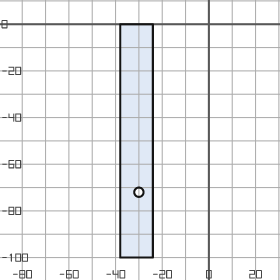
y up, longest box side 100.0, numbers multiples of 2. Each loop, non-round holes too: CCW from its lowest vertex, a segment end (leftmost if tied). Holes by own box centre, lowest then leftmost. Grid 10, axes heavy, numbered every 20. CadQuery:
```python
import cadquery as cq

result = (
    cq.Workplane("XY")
    .moveTo(-38.0, -100.0)
    .lineTo(-24.0, -100.0)
    .lineTo(-24.0, 0.0)
    .lineTo(-38.0, 0.0)
    .close()
    .moveTo(-30.0, -72.0)
    .circle(2.0)
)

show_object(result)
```